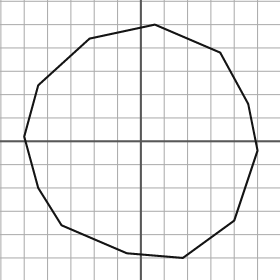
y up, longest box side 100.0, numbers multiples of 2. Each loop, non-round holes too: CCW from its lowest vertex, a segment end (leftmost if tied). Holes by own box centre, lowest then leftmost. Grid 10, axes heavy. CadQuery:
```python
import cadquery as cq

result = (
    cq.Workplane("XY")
    .moveTo(18.0, -50.0)
    .lineTo(40.0, -34.0)
    .lineTo(50.0, -4.0)
    .lineTo(46.0, 16.0)
    .lineTo(34.0, 38.0)
    .lineTo(6.0, 50.0)
    .lineTo(-22.0, 44.0)
    .lineTo(-44.0, 24.0)
    .lineTo(-50.0, 2.0)
    .lineTo(-44.0, -20.0)
    .lineTo(-34.0, -36.0)
    .lineTo(-6.0, -48.0)
    .close()
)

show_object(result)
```